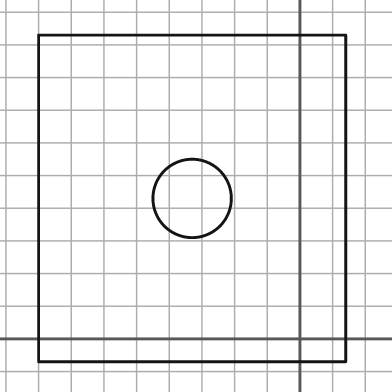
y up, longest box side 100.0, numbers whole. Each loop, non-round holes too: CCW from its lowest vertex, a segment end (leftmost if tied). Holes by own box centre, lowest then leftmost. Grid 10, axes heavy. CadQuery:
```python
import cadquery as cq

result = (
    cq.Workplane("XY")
    .moveTo(-80.0, -7.0)
    .lineTo(14.0, -7.0)
    .lineTo(14.0, 93.0)
    .lineTo(-80.0, 93.0)
    .close()
    .moveTo(-33.0, 43.0)
    .circle(12.0)
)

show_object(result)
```